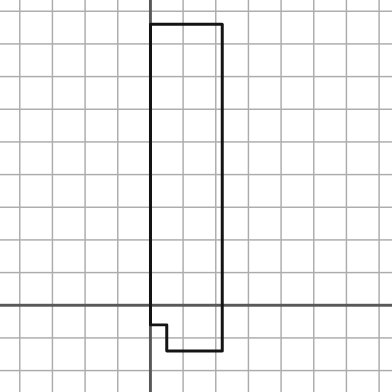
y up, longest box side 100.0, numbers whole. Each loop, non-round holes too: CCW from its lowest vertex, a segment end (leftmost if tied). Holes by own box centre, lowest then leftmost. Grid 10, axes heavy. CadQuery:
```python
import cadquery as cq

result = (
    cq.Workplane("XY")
    .moveTo(5.0, -14.0)
    .lineTo(22.0, -14.0)
    .lineTo(22.0, 86.0)
    .lineTo(0.0, 86.0)
    .lineTo(0.0, -6.0)
    .lineTo(5.0, -6.0)
    .close()
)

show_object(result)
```